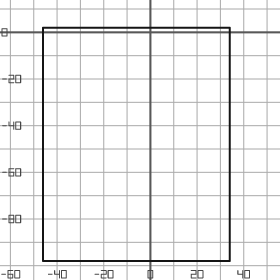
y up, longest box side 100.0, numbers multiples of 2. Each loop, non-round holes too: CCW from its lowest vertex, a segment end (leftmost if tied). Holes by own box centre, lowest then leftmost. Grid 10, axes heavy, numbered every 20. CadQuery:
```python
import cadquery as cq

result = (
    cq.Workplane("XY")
    .moveTo(-46.0, -98.0)
    .lineTo(34.0, -98.0)
    .lineTo(34.0, 2.0)
    .lineTo(-46.0, 2.0)
    .close()
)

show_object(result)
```